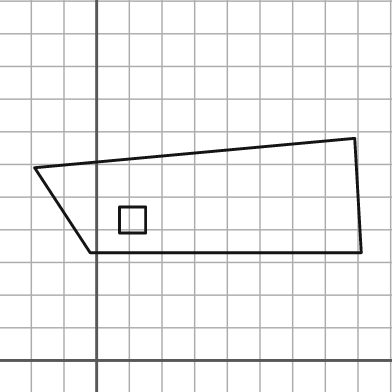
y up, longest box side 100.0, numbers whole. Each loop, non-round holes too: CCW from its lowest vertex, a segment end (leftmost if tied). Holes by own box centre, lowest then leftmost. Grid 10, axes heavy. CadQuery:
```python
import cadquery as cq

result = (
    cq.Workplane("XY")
    .moveTo(-2.0, 33.0)
    .lineTo(81.0, 33.0)
    .lineTo(79.0, 68.0)
    .lineTo(-19.0, 59.0)
    .close()
    .moveTo(7.0, 39.0)
    .lineTo(15.0, 39.0)
    .lineTo(15.0, 47.0)
    .lineTo(7.0, 47.0)
    .close()
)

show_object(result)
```